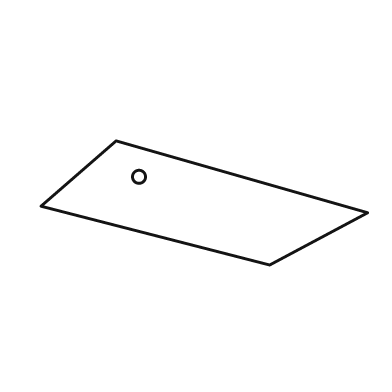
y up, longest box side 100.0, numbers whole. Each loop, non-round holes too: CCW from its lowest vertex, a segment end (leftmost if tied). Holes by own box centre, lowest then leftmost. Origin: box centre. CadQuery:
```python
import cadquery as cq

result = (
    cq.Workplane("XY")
    .moveTo(20.0, -19.0)
    .lineTo(50.0, -3.0)
    .lineTo(-27.0, 19.0)
    .lineTo(-50.0, -1.0)
    .close()
    .moveTo(-20.0, 8.0)
    .circle(2.0)
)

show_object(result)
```